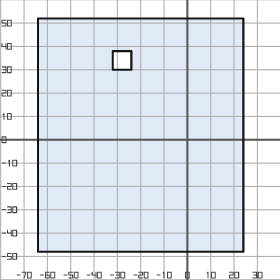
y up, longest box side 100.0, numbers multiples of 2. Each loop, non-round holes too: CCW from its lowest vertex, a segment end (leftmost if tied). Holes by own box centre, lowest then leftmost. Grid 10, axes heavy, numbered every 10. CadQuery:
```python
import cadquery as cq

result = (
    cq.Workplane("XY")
    .moveTo(-64.0, -48.0)
    .lineTo(24.0, -48.0)
    .lineTo(24.0, 52.0)
    .lineTo(-64.0, 52.0)
    .close()
    .moveTo(-32.0, 30.0)
    .lineTo(-24.0, 30.0)
    .lineTo(-24.0, 38.0)
    .lineTo(-32.0, 38.0)
    .close()
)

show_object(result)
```